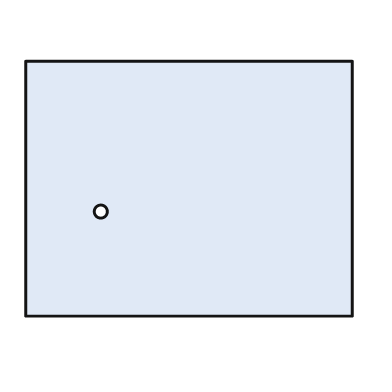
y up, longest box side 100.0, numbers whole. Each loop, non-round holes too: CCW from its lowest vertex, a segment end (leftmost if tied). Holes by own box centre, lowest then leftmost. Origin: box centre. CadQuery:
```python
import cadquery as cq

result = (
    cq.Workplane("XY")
    .moveTo(-50.0, -39.0)
    .lineTo(50.0, -39.0)
    .lineTo(50.0, 39.0)
    .lineTo(-50.0, 39.0)
    .close()
    .moveTo(-27.0, -7.0)
    .circle(2.0)
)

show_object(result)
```